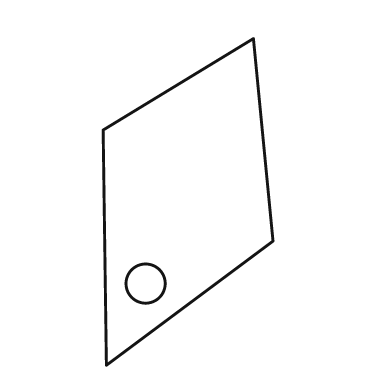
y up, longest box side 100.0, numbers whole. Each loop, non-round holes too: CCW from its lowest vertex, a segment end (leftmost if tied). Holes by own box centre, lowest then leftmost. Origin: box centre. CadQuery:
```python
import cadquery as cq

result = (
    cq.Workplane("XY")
    .moveTo(-25.0, -50.0)
    .lineTo(26.0, -12.0)
    .lineTo(20.0, 50.0)
    .lineTo(-26.0, 22.0)
    .close()
    .moveTo(-13.0, -25.0)
    .circle(6.0)
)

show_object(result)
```